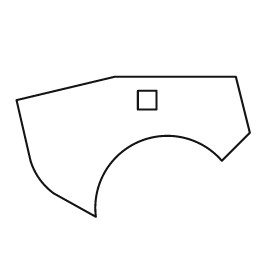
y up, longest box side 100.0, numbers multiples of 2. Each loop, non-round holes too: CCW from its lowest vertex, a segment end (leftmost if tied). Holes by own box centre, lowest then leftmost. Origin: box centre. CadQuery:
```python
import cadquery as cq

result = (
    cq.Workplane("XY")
    .moveTo(-16.0, -30.0)
    .threePointArc((2.0, 2.0), (38.0, -6.0))
    .lineTo(50.0, 6.0)
    .lineTo(44.0, 30.0)
    .lineTo(-8.0, 30.0)
    .lineTo(-50.0, 20.0)
    .lineTo(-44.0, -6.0)
    .threePointArc((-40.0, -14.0), (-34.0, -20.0))
    .close()
    .moveTo(2.0, 16.0)
    .lineTo(10.0, 16.0)
    .lineTo(10.0, 24.0)
    .lineTo(2.0, 24.0)
    .close()
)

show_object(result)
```